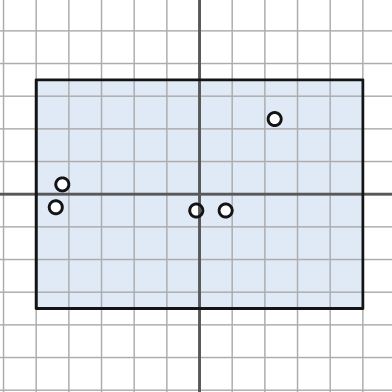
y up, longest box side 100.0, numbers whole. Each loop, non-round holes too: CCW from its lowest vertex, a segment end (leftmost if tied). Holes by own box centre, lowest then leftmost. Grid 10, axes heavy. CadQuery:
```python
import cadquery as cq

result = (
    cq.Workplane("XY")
    .moveTo(-50.0, -35.0)
    .lineTo(50.0, -35.0)
    .lineTo(50.0, 35.0)
    .lineTo(-50.0, 35.0)
    .close()
    .moveTo(-1.0, -5.0)
    .circle(2.0)
    .moveTo(8.0, -5.0)
    .circle(2.0)
    .moveTo(-44.0, -4.0)
    .circle(2.0)
    .moveTo(-42.0, 3.0)
    .circle(2.0)
    .moveTo(23.0, 23.0)
    .circle(2.0)
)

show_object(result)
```